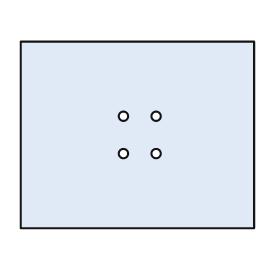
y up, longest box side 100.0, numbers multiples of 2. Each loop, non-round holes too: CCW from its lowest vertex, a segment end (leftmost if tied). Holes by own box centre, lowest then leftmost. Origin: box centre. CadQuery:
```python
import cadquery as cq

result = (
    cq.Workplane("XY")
    .moveTo(-50.0, -40.0)
    .lineTo(50.0, -40.0)
    .lineTo(50.0, 40.0)
    .lineTo(-50.0, 40.0)
    .close()
    .moveTo(-6.0, -8.0)
    .circle(2.0)
    .moveTo(8.0, -8.0)
    .circle(2.0)
    .moveTo(-6.0, 8.0)
    .circle(2.0)
    .moveTo(8.0, 8.0)
    .circle(2.0)
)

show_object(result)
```